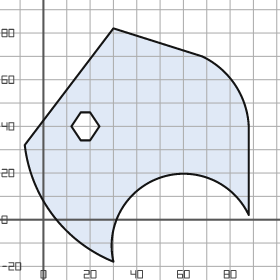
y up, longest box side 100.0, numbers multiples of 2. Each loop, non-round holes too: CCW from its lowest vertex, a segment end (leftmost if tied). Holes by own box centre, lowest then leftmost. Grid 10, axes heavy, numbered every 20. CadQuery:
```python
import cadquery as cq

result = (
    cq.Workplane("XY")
    .moveTo(30.0, -18.0)
    .threePointArc((50.0, 18.0), (88.0, 2.0))
    .lineTo(88.0, 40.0)
    .threePointArc((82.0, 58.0), (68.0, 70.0))
    .lineTo(30.0, 82.0)
    .lineTo(-8.0, 32.0)
    .threePointArc((4.0, 2.0), (30.0, -18.0))
    .close()
    .moveTo(16.0, 34.0)
    .lineTo(20.0, 34.0)
    .lineTo(24.0, 40.0)
    .lineTo(20.0, 46.0)
    .lineTo(16.0, 46.0)
    .lineTo(12.0, 40.0)
    .close()
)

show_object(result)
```